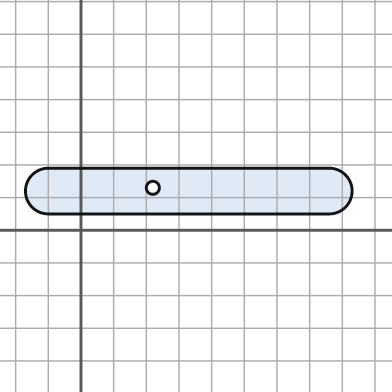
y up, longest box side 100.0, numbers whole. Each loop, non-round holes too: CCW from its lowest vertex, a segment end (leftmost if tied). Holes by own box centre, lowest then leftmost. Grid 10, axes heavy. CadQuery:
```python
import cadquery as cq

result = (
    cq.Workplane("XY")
    .moveTo(-10.0, 5.0)
    .lineTo(76.0, 5.0)
    .threePointArc((83.0, 12.0), (76.0, 19.0))
    .lineTo(-10.0, 19.0)
    .threePointArc((-17.0, 12.0), (-10.0, 5.0))
    .close()
    .moveTo(22.0, 13.0)
    .circle(2.0)
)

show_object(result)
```